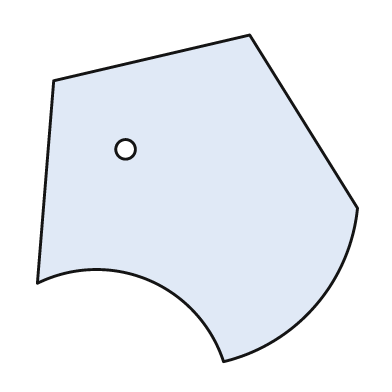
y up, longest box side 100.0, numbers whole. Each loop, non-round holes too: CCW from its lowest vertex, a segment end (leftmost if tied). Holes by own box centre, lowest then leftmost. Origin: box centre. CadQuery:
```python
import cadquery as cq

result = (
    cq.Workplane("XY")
    .moveTo(8.0, -50.0)
    .threePointArc((36.0, -33.0), (49.0, -3.0))
    .lineTo(16.0, 50.0)
    .lineTo(-44.0, 36.0)
    .lineTo(-49.0, -26.0)
    .threePointArc((-15.0, -25.0), (8.0, -50.0))
    .close()
    .moveTo(-22.0, 15.0)
    .circle(3.0)
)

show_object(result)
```